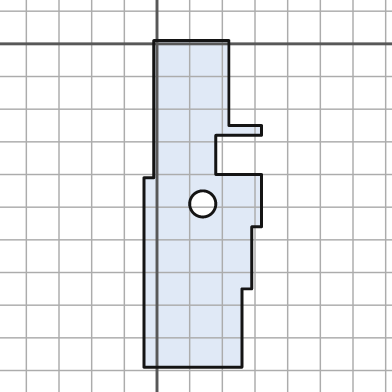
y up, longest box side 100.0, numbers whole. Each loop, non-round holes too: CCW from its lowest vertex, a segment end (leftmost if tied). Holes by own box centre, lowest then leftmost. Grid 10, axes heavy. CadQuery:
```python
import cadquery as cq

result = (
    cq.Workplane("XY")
    .moveTo(-4.0, -99.0)
    .lineTo(26.0, -99.0)
    .lineTo(26.0, -75.0)
    .lineTo(29.0, -75.0)
    .lineTo(29.0, -56.0)
    .lineTo(32.0, -56.0)
    .lineTo(32.0, -40.0)
    .lineTo(18.0, -40.0)
    .lineTo(18.0, -28.0)
    .lineTo(32.0, -28.0)
    .lineTo(32.0, -25.0)
    .lineTo(22.0, -25.0)
    .lineTo(22.0, 1.0)
    .lineTo(-1.0, 1.0)
    .lineTo(-1.0, -41.0)
    .lineTo(-4.0, -41.0)
    .close()
    .moveTo(14.0, -49.0)
    .circle(4.0)
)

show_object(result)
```